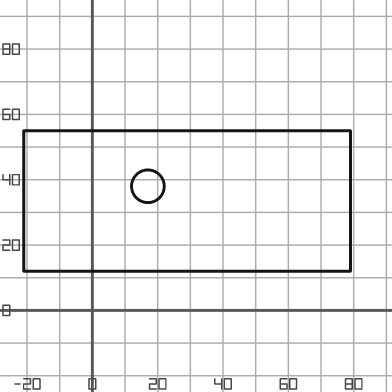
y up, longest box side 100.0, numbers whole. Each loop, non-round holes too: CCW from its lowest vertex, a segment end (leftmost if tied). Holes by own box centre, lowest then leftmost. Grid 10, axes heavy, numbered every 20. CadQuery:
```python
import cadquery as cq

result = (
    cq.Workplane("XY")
    .moveTo(-21.0, 12.0)
    .lineTo(79.0, 12.0)
    .lineTo(79.0, 55.0)
    .lineTo(-21.0, 55.0)
    .close()
    .moveTo(17.0, 38.0)
    .circle(5.0)
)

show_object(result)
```